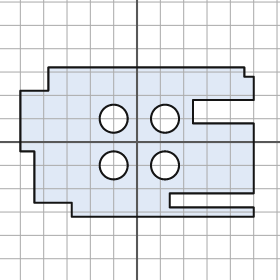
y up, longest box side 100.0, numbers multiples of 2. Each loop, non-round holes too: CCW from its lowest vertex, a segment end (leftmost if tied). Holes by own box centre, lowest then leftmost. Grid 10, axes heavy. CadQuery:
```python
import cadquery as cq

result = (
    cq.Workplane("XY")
    .moveTo(-28.0, -32.0)
    .lineTo(50.0, -32.0)
    .lineTo(50.0, -28.0)
    .lineTo(14.0, -28.0)
    .lineTo(14.0, -22.0)
    .lineTo(50.0, -22.0)
    .lineTo(50.0, 8.0)
    .lineTo(24.0, 8.0)
    .lineTo(24.0, 18.0)
    .lineTo(50.0, 18.0)
    .lineTo(50.0, 28.0)
    .lineTo(46.0, 28.0)
    .lineTo(46.0, 32.0)
    .lineTo(-38.0, 32.0)
    .lineTo(-38.0, 22.0)
    .lineTo(-50.0, 22.0)
    .lineTo(-50.0, -4.0)
    .lineTo(-44.0, -4.0)
    .lineTo(-44.0, -26.0)
    .lineTo(-28.0, -26.0)
    .close()
    .moveTo(-10.0, -10.0)
    .circle(6.0)
    .moveTo(12.0, -10.0)
    .circle(6.0)
    .moveTo(-10.0, 10.0)
    .circle(6.0)
    .moveTo(12.0, 10.0)
    .circle(6.0)
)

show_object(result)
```